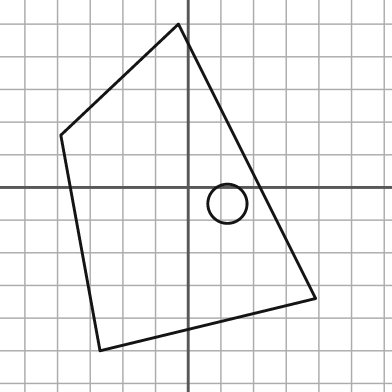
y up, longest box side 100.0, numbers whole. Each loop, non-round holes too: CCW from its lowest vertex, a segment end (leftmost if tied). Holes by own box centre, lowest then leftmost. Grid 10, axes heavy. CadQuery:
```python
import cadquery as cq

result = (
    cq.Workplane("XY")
    .moveTo(-27.0, -50.0)
    .lineTo(39.0, -34.0)
    .lineTo(-3.0, 50.0)
    .lineTo(-39.0, 16.0)
    .close()
    .moveTo(12.0, -5.0)
    .circle(6.0)
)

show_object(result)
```